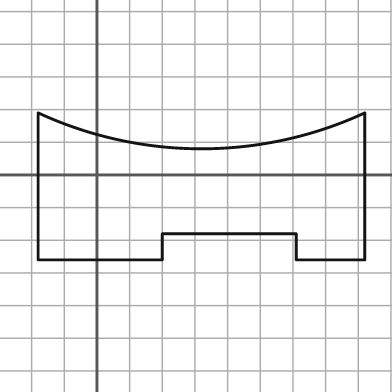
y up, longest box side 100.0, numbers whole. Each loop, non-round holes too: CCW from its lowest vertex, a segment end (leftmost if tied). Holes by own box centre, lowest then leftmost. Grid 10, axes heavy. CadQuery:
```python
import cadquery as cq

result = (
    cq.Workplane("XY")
    .moveTo(-18.0, -26.0)
    .lineTo(20.0, -26.0)
    .lineTo(20.0, -18.0)
    .lineTo(61.0, -18.0)
    .lineTo(61.0, -26.0)
    .lineTo(82.0, -26.0)
    .lineTo(82.0, 19.0)
    .threePointArc((32.0, 8.0), (-18.0, 19.0))
    .close()
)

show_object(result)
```